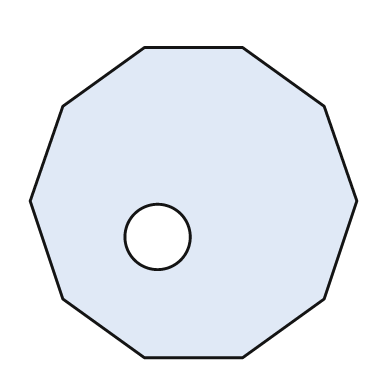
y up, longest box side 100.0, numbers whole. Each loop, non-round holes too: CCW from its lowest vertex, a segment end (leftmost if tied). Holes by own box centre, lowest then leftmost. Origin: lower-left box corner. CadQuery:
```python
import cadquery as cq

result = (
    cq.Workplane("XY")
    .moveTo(35.0, 0.0)
    .lineTo(65.0, 0.0)
    .lineTo(90.0, 18.0)
    .lineTo(100.0, 48.0)
    .lineTo(90.0, 77.0)
    .lineTo(65.0, 95.0)
    .lineTo(35.0, 95.0)
    .lineTo(10.0, 77.0)
    .lineTo(0.0, 48.0)
    .lineTo(10.0, 18.0)
    .close()
    .moveTo(39.0, 37.0)
    .circle(10.0)
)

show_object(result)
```